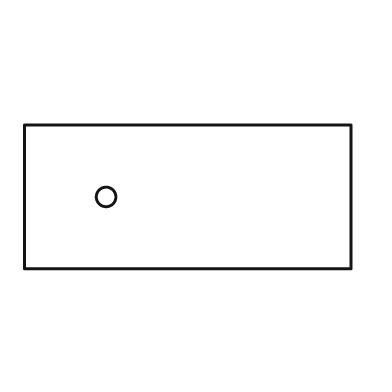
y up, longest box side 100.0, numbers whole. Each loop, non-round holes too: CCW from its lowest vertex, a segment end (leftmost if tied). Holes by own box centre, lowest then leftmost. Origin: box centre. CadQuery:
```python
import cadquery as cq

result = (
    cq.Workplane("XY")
    .moveTo(-50.0, -22.0)
    .lineTo(50.0, -22.0)
    .lineTo(50.0, 22.0)
    .lineTo(-50.0, 22.0)
    .close()
    .moveTo(-25.0, 0.0)
    .circle(3.0)
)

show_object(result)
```